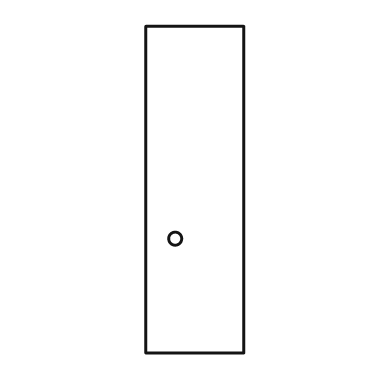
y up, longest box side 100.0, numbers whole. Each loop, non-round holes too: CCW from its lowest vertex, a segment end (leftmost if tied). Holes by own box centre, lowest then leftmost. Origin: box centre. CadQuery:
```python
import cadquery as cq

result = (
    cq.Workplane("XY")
    .moveTo(-15.0, -50.0)
    .lineTo(15.0, -50.0)
    .lineTo(15.0, 50.0)
    .lineTo(-15.0, 50.0)
    .close()
    .moveTo(-6.0, -15.0)
    .circle(2.0)
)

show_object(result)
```